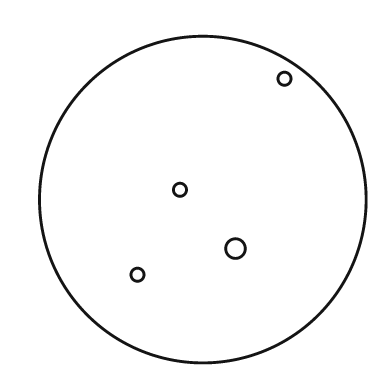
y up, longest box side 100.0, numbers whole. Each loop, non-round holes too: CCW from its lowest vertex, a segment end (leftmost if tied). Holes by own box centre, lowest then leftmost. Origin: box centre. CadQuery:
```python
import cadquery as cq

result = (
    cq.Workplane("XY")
    .moveTo(0.0, 0.0)
    .circle(50.0)
    .moveTo(-20.0, -23.0)
    .circle(2.0)
    .moveTo(10.0, -15.0)
    .circle(3.0)
    .moveTo(-7.0, 3.0)
    .circle(2.0)
    .moveTo(25.0, 37.0)
    .circle(2.0)
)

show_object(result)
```